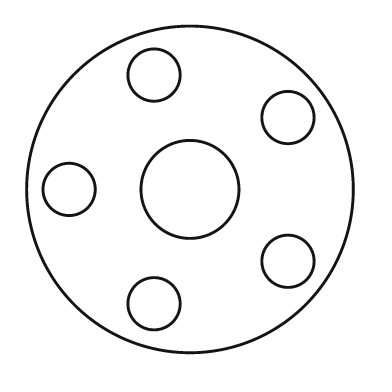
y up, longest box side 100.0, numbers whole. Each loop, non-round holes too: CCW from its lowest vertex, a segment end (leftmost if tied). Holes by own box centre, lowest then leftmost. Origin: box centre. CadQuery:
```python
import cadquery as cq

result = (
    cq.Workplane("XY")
    .moveTo(0.0, 0.0)
    .circle(50.0)
    .moveTo(-11.0, -35.0)
    .circle(8.0)
    .moveTo(30.0, -22.0)
    .circle(8.0)
    .moveTo(-37.0, 0.0)
    .circle(8.0)
    .moveTo(0.0, 0.0)
    .circle(15.0)
    .moveTo(30.0, 22.0)
    .circle(8.0)
    .moveTo(-11.0, 35.0)
    .circle(8.0)
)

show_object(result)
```